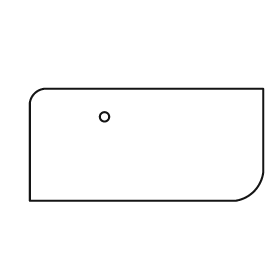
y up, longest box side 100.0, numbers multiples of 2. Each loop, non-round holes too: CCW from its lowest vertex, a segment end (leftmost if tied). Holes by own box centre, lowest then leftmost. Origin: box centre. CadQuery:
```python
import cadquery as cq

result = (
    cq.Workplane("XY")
    .moveTo(-50.0, -24.0)
    .lineTo(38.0, -24.0)
    .threePointArc((46.0, -20.0), (50.0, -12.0))
    .lineTo(50.0, 24.0)
    .lineTo(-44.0, 24.0)
    .threePointArc((-48.0, 22.0), (-50.0, 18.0))
    .close()
    .moveTo(-18.0, 12.0)
    .circle(2.0)
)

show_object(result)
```